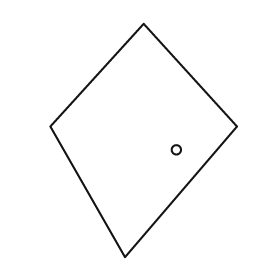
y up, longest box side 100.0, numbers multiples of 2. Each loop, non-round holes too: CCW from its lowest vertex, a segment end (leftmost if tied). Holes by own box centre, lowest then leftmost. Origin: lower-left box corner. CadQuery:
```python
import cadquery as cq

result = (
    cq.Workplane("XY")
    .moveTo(32.0, 0.0)
    .lineTo(80.0, 56.0)
    .lineTo(40.0, 100.0)
    .lineTo(0.0, 56.0)
    .close()
    .moveTo(54.0, 46.0)
    .circle(2.0)
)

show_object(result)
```